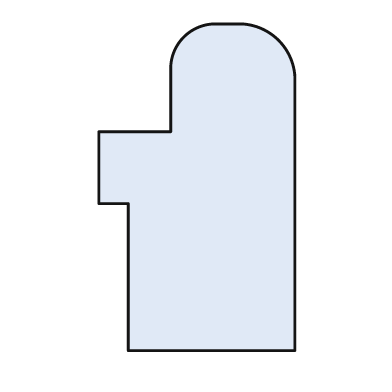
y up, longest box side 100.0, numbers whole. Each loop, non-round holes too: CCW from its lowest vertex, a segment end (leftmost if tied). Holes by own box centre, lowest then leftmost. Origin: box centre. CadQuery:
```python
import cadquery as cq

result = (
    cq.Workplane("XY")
    .moveTo(-21.0, -50.0)
    .lineTo(30.0, -50.0)
    .lineTo(30.0, 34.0)
    .threePointArc((25.0, 45.0), (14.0, 50.0))
    .lineTo(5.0, 50.0)
    .threePointArc((-4.0, 46.0), (-8.0, 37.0))
    .lineTo(-8.0, 17.0)
    .lineTo(-30.0, 17.0)
    .lineTo(-30.0, -5.0)
    .lineTo(-21.0, -5.0)
    .close()
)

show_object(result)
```